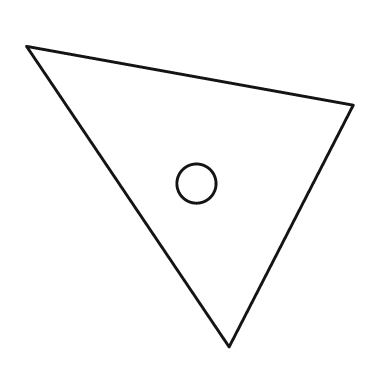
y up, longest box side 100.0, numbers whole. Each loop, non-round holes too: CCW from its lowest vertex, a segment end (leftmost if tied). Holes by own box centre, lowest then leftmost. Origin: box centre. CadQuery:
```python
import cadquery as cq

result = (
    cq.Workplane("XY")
    .moveTo(12.0, -46.0)
    .lineTo(50.0, 28.0)
    .lineTo(-50.0, 46.0)
    .close()
    .moveTo(2.0, 4.0)
    .circle(6.0)
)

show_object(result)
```